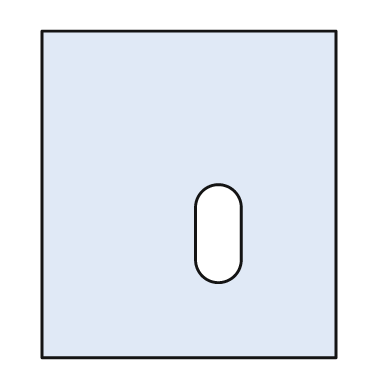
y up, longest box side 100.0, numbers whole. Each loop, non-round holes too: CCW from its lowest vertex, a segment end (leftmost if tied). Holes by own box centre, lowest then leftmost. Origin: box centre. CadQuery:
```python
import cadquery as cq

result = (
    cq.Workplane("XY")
    .moveTo(-45.0, -50.0)
    .lineTo(45.0, -50.0)
    .lineTo(45.0, 50.0)
    .lineTo(-45.0, 50.0)
    .close()
    .moveTo(2.0, -20.0)
    .threePointArc((9.0, -27.0), (16.0, -20.0))
    .lineTo(16.0, -4.0)
    .threePointArc((9.0, 3.0), (2.0, -4.0))
    .close()
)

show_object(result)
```